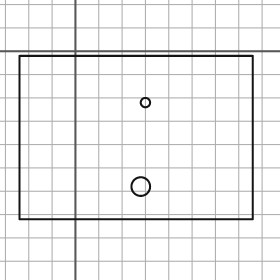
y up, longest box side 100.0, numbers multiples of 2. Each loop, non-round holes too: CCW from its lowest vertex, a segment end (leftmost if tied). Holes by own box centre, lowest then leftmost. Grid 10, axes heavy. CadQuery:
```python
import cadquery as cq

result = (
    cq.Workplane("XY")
    .moveTo(-24.0, -72.0)
    .lineTo(76.0, -72.0)
    .lineTo(76.0, -2.0)
    .lineTo(-24.0, -2.0)
    .close()
    .moveTo(28.0, -58.0)
    .circle(4.0)
    .moveTo(30.0, -22.0)
    .circle(2.0)
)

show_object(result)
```